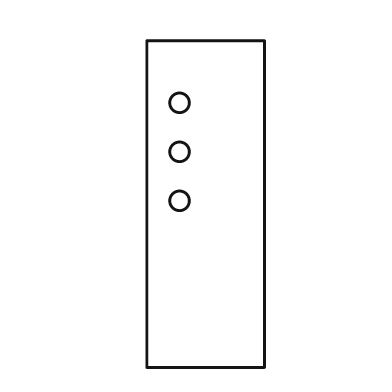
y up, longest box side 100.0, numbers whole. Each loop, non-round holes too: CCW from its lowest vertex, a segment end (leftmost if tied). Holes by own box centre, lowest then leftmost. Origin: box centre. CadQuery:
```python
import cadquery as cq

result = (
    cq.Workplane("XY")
    .moveTo(-18.0, -50.0)
    .lineTo(18.0, -50.0)
    .lineTo(18.0, 50.0)
    .lineTo(-18.0, 50.0)
    .close()
    .moveTo(-8.0, 1.0)
    .circle(3.0)
    .moveTo(-8.0, 16.0)
    .circle(3.0)
    .moveTo(-8.0, 31.0)
    .circle(3.0)
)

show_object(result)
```